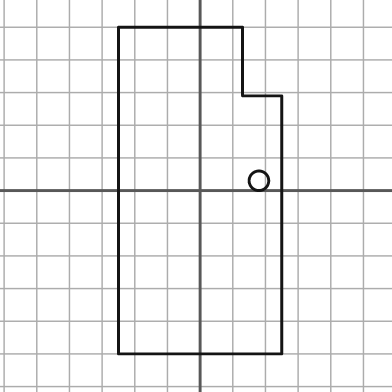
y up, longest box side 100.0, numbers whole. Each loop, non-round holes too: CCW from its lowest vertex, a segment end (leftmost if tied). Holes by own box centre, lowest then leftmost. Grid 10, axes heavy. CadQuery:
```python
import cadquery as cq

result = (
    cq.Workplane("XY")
    .moveTo(-25.0, -50.0)
    .lineTo(25.0, -50.0)
    .lineTo(25.0, 29.0)
    .lineTo(13.0, 29.0)
    .lineTo(13.0, 50.0)
    .lineTo(-25.0, 50.0)
    .close()
    .moveTo(18.0, 3.0)
    .circle(3.0)
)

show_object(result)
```